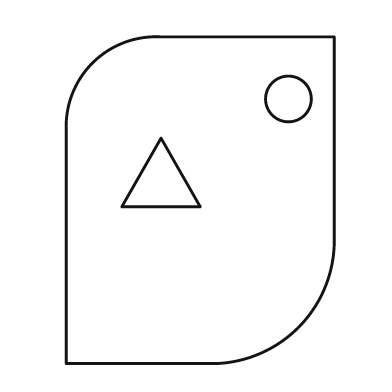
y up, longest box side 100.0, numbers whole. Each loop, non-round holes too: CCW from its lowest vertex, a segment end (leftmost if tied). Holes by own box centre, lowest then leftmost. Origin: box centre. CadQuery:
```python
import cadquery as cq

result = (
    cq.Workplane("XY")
    .moveTo(-41.0, -50.0)
    .lineTo(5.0, -50.0)
    .threePointArc((30.0, -39.0), (41.0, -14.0))
    .lineTo(41.0, 50.0)
    .lineTo(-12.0, 50.0)
    .threePointArc((-33.0, 42.0), (-41.0, 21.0))
    .close()
    .moveTo(-24.0, -2.0)
    .lineTo(0.0, -2.0)
    .lineTo(-12.0, 19.0)
    .close()
    .moveTo(27.0, 31.0)
    .circle(7.0)
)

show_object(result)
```